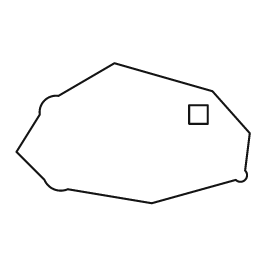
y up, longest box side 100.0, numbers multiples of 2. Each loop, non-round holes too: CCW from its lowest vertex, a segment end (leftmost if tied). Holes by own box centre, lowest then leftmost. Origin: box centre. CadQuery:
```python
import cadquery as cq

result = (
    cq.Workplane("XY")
    .moveTo(8.0, -30.0)
    .lineTo(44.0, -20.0)
    .threePointArc((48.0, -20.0), (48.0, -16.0))
    .lineTo(50.0, 0.0)
    .lineTo(34.0, 18.0)
    .lineTo(-8.0, 30.0)
    .lineTo(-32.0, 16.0)
    .threePointArc((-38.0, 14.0), (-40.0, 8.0))
    .lineTo(-50.0, -8.0)
    .lineTo(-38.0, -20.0)
    .threePointArc((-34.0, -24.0), (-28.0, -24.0))
    .close()
    .moveTo(24.0, 4.0)
    .lineTo(32.0, 4.0)
    .lineTo(32.0, 12.0)
    .lineTo(24.0, 12.0)
    .close()
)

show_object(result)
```